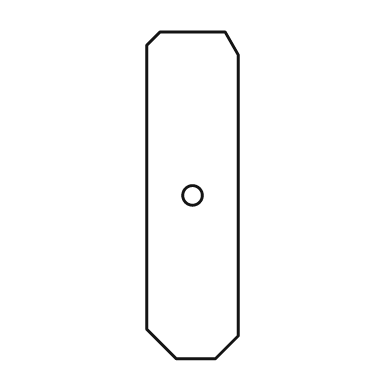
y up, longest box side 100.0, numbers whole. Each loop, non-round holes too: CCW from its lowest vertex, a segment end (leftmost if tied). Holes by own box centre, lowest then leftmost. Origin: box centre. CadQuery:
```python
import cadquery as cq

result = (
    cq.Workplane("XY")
    .moveTo(-5.0, -50.0)
    .lineTo(7.0, -50.0)
    .lineTo(14.0, -43.0)
    .lineTo(14.0, 43.0)
    .lineTo(10.0, 50.0)
    .lineTo(-10.0, 50.0)
    .lineTo(-14.0, 46.0)
    .lineTo(-14.0, -41.0)
    .close()
    .moveTo(0.0, 0.0)
    .circle(3.0)
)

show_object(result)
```